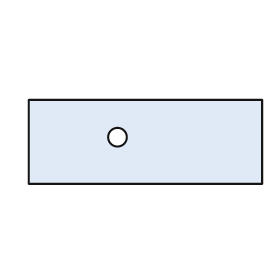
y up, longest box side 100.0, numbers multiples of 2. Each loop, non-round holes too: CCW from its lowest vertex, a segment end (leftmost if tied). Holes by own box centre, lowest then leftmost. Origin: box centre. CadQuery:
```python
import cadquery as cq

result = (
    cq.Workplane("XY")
    .moveTo(-50.0, -18.0)
    .lineTo(50.0, -18.0)
    .lineTo(50.0, 18.0)
    .lineTo(-50.0, 18.0)
    .close()
    .moveTo(-12.0, 2.0)
    .circle(4.0)
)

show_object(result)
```